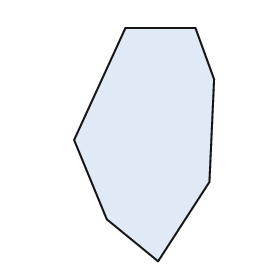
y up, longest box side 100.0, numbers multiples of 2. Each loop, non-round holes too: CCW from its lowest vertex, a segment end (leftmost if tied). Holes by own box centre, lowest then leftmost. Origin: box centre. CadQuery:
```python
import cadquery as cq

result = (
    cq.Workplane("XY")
    .moveTo(6.0, -50.0)
    .lineTo(28.0, -16.0)
    .lineTo(30.0, 28.0)
    .lineTo(22.0, 50.0)
    .lineTo(-8.0, 50.0)
    .lineTo(-30.0, 2.0)
    .lineTo(-16.0, -32.0)
    .close()
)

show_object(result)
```